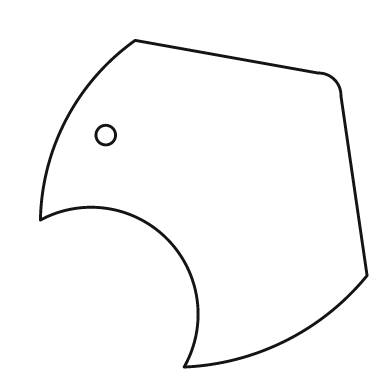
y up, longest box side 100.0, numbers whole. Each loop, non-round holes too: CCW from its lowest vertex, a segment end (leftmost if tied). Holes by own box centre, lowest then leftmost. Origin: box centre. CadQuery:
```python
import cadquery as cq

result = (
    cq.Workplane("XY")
    .moveTo(-6.0, -50.0)
    .threePointArc((25.0, -42.0), (50.0, -22.0))
    .lineTo(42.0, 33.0)
    .threePointArc((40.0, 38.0), (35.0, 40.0))
    .lineTo(-21.0, 50.0)
    .threePointArc((-42.0, 26.0), (-50.0, -5.0))
    .threePointArc((-11.0, -11.0), (-6.0, -50.0))
    .close()
    .moveTo(-30.0, 21.0)
    .circle(3.0)
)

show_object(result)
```